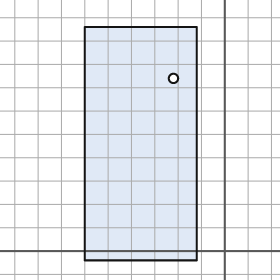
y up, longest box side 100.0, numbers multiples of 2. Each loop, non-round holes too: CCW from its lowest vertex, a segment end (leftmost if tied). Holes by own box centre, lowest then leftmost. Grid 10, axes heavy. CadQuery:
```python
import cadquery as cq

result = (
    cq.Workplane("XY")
    .moveTo(-60.0, -4.0)
    .lineTo(-12.0, -4.0)
    .lineTo(-12.0, 96.0)
    .lineTo(-60.0, 96.0)
    .close()
    .moveTo(-22.0, 74.0)
    .circle(2.0)
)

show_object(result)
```